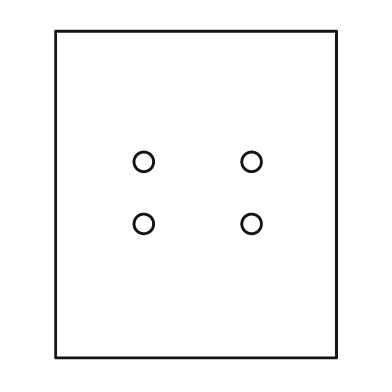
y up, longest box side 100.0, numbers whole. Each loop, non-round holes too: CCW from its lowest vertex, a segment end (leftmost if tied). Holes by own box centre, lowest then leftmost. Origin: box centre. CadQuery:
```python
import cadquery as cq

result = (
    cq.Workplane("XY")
    .moveTo(-43.0, -50.0)
    .lineTo(43.0, -50.0)
    .lineTo(43.0, 50.0)
    .lineTo(-43.0, 50.0)
    .close()
    .moveTo(-16.0, -9.0)
    .circle(3.0)
    .moveTo(17.0, -9.0)
    .circle(3.0)
    .moveTo(-16.0, 10.0)
    .circle(3.0)
    .moveTo(17.0, 10.0)
    .circle(3.0)
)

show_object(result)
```